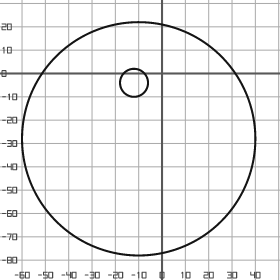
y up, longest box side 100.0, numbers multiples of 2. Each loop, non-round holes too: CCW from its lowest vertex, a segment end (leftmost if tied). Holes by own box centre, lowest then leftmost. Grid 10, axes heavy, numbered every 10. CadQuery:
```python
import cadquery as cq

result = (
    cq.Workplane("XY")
    .moveTo(-10.0, -28.0)
    .circle(50.0)
    .moveTo(-12.0, -4.0)
    .circle(6.0)
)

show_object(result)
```